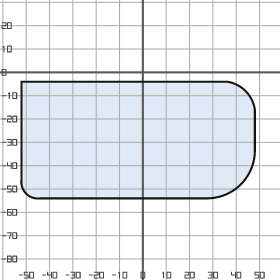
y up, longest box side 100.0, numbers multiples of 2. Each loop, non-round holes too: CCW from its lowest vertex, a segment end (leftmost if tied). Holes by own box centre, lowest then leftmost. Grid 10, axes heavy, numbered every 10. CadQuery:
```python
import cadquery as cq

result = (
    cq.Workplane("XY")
    .moveTo(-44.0, -54.0)
    .lineTo(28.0, -54.0)
    .threePointArc((42.0, -48.0), (48.0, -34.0))
    .lineTo(48.0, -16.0)
    .threePointArc((44.0, -8.0), (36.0, -4.0))
    .lineTo(-52.0, -4.0)
    .lineTo(-52.0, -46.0)
    .threePointArc((-50.0, -52.0), (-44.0, -54.0))
    .close()
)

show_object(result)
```